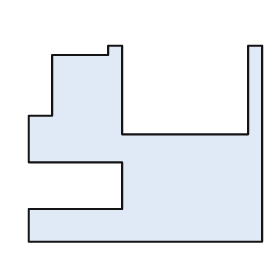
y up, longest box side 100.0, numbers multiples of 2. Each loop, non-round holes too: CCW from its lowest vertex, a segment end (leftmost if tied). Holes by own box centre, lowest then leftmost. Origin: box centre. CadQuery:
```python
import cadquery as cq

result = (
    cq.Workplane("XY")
    .moveTo(-50.0, -42.0)
    .lineTo(50.0, -42.0)
    .lineTo(50.0, 42.0)
    .lineTo(44.0, 42.0)
    .lineTo(44.0, 4.0)
    .lineTo(-10.0, 4.0)
    .lineTo(-10.0, 42.0)
    .lineTo(-16.0, 42.0)
    .lineTo(-16.0, 38.0)
    .lineTo(-40.0, 38.0)
    .lineTo(-40.0, 12.0)
    .lineTo(-50.0, 12.0)
    .lineTo(-50.0, -8.0)
    .lineTo(-10.0, -8.0)
    .lineTo(-10.0, -28.0)
    .lineTo(-50.0, -28.0)
    .close()
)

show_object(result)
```